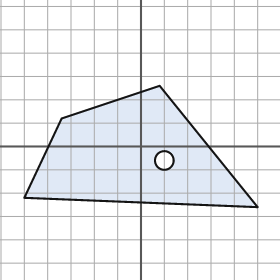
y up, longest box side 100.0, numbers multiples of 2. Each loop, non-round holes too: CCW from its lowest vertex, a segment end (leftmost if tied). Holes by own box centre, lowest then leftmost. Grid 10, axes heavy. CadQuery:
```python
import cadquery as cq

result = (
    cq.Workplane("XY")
    .moveTo(50.0, -26.0)
    .lineTo(8.0, 26.0)
    .lineTo(-34.0, 12.0)
    .lineTo(-50.0, -22.0)
    .close()
    .moveTo(10.0, -6.0)
    .circle(4.0)
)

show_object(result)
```